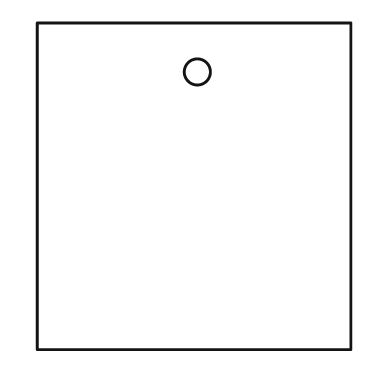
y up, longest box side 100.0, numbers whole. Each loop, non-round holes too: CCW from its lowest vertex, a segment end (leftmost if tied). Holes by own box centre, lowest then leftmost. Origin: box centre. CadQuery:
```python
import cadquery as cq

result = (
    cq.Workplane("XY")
    .moveTo(-48.0, -50.0)
    .lineTo(48.0, -50.0)
    .lineTo(48.0, 50.0)
    .lineTo(-48.0, 50.0)
    .close()
    .moveTo(1.0, 35.0)
    .circle(4.0)
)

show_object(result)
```